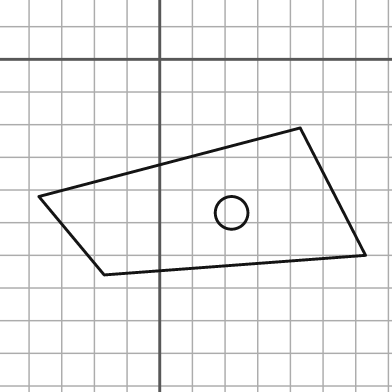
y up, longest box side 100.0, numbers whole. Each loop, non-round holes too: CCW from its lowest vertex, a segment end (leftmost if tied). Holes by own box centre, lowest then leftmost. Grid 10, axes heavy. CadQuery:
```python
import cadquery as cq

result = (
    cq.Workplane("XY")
    .moveTo(-17.0, -66.0)
    .lineTo(63.0, -60.0)
    .lineTo(43.0, -21.0)
    .lineTo(-37.0, -42.0)
    .close()
    .moveTo(22.0, -47.0)
    .circle(5.0)
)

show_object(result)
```